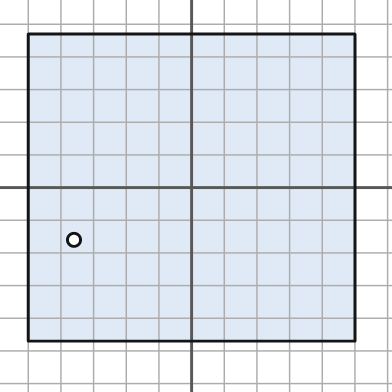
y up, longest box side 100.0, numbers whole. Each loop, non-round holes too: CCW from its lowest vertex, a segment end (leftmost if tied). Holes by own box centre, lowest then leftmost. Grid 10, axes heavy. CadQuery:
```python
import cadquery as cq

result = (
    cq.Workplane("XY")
    .moveTo(-50.0, -47.0)
    .lineTo(50.0, -47.0)
    .lineTo(50.0, 47.0)
    .lineTo(-50.0, 47.0)
    .close()
    .moveTo(-36.0, -16.0)
    .circle(2.0)
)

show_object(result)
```